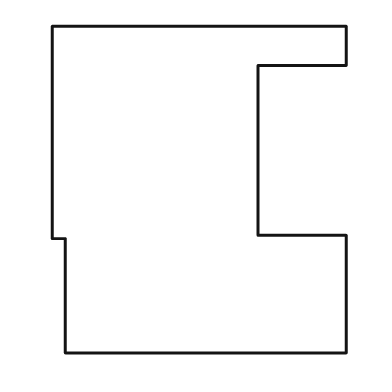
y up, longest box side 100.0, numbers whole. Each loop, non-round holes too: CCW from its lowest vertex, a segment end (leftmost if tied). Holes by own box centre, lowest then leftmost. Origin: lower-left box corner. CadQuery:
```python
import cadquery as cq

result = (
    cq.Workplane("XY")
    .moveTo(4.0, 0.0)
    .lineTo(90.0, 0.0)
    .lineTo(90.0, 36.0)
    .lineTo(63.0, 36.0)
    .lineTo(63.0, 88.0)
    .lineTo(90.0, 88.0)
    .lineTo(90.0, 100.0)
    .lineTo(0.0, 100.0)
    .lineTo(0.0, 35.0)
    .lineTo(4.0, 35.0)
    .close()
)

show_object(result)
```